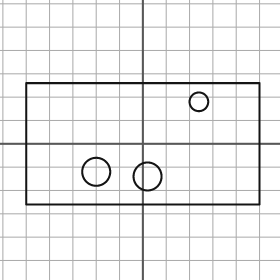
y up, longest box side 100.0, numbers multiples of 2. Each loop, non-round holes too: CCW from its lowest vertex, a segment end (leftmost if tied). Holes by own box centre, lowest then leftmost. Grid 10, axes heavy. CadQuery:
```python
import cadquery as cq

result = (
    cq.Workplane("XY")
    .moveTo(-50.0, -26.0)
    .lineTo(50.0, -26.0)
    .lineTo(50.0, 26.0)
    .lineTo(-50.0, 26.0)
    .close()
    .moveTo(2.0, -14.0)
    .circle(6.0)
    .moveTo(-20.0, -12.0)
    .circle(6.0)
    .moveTo(24.0, 18.0)
    .circle(4.0)
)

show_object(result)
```